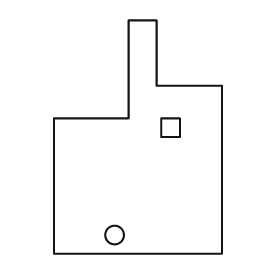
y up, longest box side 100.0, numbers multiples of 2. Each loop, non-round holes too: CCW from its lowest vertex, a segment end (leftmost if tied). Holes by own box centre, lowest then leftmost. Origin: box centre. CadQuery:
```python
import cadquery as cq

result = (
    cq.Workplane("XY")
    .moveTo(-36.0, -50.0)
    .lineTo(36.0, -50.0)
    .lineTo(36.0, 22.0)
    .lineTo(8.0, 22.0)
    .lineTo(8.0, 50.0)
    .lineTo(-4.0, 50.0)
    .lineTo(-4.0, 8.0)
    .lineTo(-36.0, 8.0)
    .close()
    .moveTo(-10.0, -42.0)
    .circle(4.0)
    .moveTo(10.0, 0.0)
    .lineTo(18.0, 0.0)
    .lineTo(18.0, 8.0)
    .lineTo(10.0, 8.0)
    .close()
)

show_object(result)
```